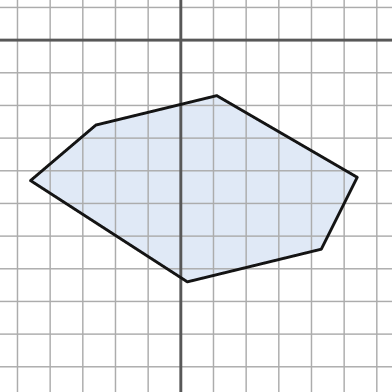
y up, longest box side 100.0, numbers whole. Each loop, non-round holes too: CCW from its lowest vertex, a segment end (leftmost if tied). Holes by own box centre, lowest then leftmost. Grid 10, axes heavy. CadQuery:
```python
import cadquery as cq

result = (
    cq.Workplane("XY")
    .moveTo(2.0, -74.0)
    .lineTo(43.0, -64.0)
    .lineTo(54.0, -42.0)
    .lineTo(11.0, -17.0)
    .lineTo(-26.0, -26.0)
    .lineTo(-46.0, -43.0)
    .close()
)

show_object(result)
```